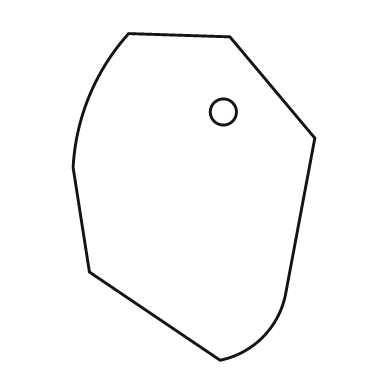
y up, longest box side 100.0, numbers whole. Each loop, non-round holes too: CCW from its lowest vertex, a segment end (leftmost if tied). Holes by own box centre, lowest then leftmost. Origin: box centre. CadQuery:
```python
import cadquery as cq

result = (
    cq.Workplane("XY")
    .moveTo(8.0, -50.0)
    .threePointArc((21.0, -43.0), (28.0, -30.0))
    .lineTo(37.0, 18.0)
    .lineTo(11.0, 49.0)
    .lineTo(-20.0, 50.0)
    .threePointArc((-32.0, 31.0), (-37.0, 9.0))
    .lineTo(-32.0, -23.0)
    .close()
    .moveTo(9.0, 26.0)
    .circle(4.0)
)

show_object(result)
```